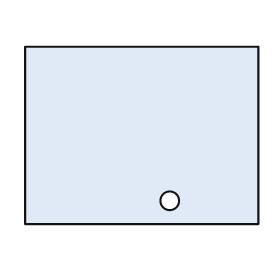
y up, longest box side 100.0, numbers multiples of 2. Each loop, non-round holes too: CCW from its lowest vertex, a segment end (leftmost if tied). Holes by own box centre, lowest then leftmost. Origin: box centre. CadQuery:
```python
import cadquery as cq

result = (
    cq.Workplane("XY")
    .moveTo(-50.0, -38.0)
    .lineTo(50.0, -38.0)
    .lineTo(50.0, 38.0)
    .lineTo(-50.0, 38.0)
    .close()
    .moveTo(12.0, -28.0)
    .circle(4.0)
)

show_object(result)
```